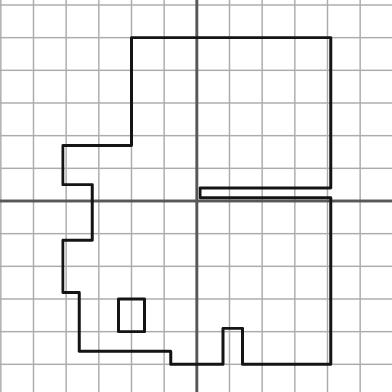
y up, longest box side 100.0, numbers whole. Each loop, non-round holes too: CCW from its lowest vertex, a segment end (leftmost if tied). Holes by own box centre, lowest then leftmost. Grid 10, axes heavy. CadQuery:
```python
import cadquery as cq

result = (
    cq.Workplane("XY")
    .moveTo(-8.0, -50.0)
    .lineTo(8.0, -50.0)
    .lineTo(8.0, -39.0)
    .lineTo(14.0, -39.0)
    .lineTo(14.0, -50.0)
    .lineTo(41.0, -50.0)
    .lineTo(41.0, 1.0)
    .lineTo(1.0, 1.0)
    .lineTo(1.0, 4.0)
    .lineTo(41.0, 4.0)
    .lineTo(41.0, 50.0)
    .lineTo(-20.0, 50.0)
    .lineTo(-20.0, 17.0)
    .lineTo(-41.0, 17.0)
    .lineTo(-41.0, 5.0)
    .lineTo(-32.0, 5.0)
    .lineTo(-32.0, -12.0)
    .lineTo(-41.0, -12.0)
    .lineTo(-41.0, -28.0)
    .lineTo(-36.0, -28.0)
    .lineTo(-36.0, -46.0)
    .lineTo(-8.0, -46.0)
    .close()
    .moveTo(-24.0, -40.0)
    .lineTo(-16.0, -40.0)
    .lineTo(-16.0, -30.0)
    .lineTo(-24.0, -30.0)
    .close()
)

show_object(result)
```